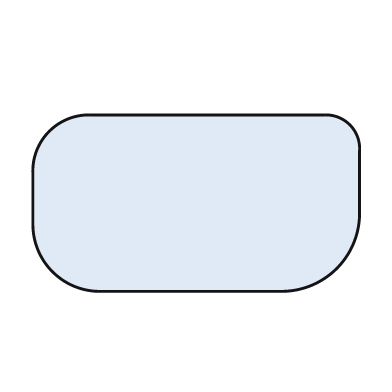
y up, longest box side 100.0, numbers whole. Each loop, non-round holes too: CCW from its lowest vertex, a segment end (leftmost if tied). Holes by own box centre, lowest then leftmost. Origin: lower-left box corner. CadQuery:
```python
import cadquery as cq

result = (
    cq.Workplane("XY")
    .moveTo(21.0, 0.0)
    .lineTo(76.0, 0.0)
    .threePointArc((93.0, 7.0), (100.0, 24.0))
    .lineTo(100.0, 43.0)
    .threePointArc((97.0, 51.0), (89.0, 54.0))
    .lineTo(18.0, 54.0)
    .threePointArc((5.0, 49.0), (0.0, 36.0))
    .lineTo(0.0, 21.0)
    .threePointArc((6.0, 6.0), (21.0, 0.0))
    .close()
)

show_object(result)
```